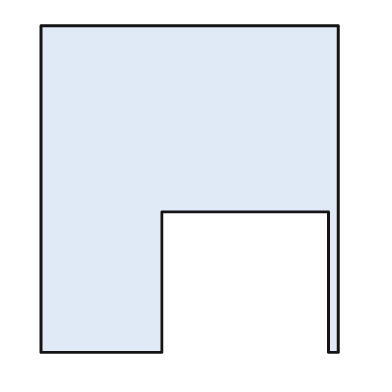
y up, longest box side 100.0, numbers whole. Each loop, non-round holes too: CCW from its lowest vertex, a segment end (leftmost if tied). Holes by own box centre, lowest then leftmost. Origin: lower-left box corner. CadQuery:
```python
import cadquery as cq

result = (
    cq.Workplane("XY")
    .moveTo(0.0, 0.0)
    .lineTo(37.0, 0.0)
    .lineTo(37.0, 43.0)
    .lineTo(88.0, 43.0)
    .lineTo(88.0, 0.0)
    .lineTo(91.0, 0.0)
    .lineTo(91.0, 100.0)
    .lineTo(0.0, 100.0)
    .close()
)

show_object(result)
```